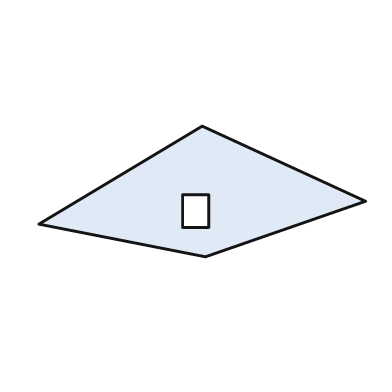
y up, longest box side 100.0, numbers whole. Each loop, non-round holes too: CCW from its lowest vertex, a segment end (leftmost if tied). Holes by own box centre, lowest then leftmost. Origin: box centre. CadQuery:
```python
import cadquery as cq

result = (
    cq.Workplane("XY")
    .moveTo(1.0, -20.0)
    .lineTo(50.0, -3.0)
    .lineTo(0.0, 20.0)
    .lineTo(-50.0, -10.0)
    .close()
    .moveTo(-6.0, -11.0)
    .lineTo(2.0, -11.0)
    .lineTo(2.0, -1.0)
    .lineTo(-6.0, -1.0)
    .close()
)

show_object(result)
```